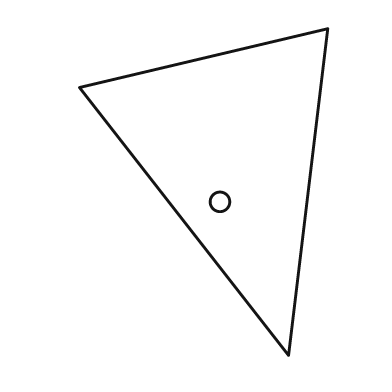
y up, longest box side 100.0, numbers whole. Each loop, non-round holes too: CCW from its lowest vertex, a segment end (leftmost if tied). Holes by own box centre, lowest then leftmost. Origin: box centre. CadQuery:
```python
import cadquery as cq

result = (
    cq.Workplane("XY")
    .moveTo(26.0, -50.0)
    .lineTo(38.0, 50.0)
    .lineTo(-38.0, 32.0)
    .close()
    .moveTo(5.0, -3.0)
    .circle(3.0)
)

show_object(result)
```